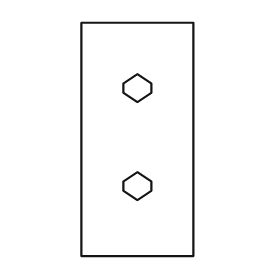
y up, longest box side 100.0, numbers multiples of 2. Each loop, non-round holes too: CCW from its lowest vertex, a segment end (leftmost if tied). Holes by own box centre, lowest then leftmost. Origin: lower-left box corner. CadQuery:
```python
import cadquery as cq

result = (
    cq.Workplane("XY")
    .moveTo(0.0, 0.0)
    .lineTo(48.0, 0.0)
    .lineTo(48.0, 100.0)
    .lineTo(0.0, 100.0)
    .close()
    .moveTo(24.0, 24.0)
    .lineTo(30.0, 28.0)
    .lineTo(30.0, 32.0)
    .lineTo(24.0, 36.0)
    .lineTo(18.0, 32.0)
    .lineTo(18.0, 28.0)
    .close()
    .moveTo(24.0, 66.0)
    .lineTo(30.0, 70.0)
    .lineTo(30.0, 74.0)
    .lineTo(24.0, 78.0)
    .lineTo(18.0, 74.0)
    .lineTo(18.0, 70.0)
    .close()
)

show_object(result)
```